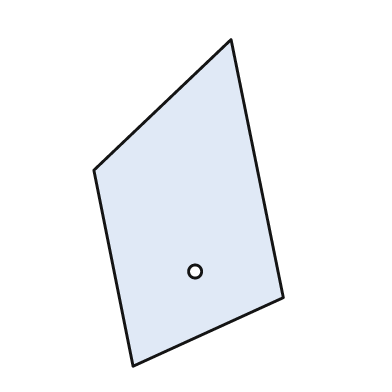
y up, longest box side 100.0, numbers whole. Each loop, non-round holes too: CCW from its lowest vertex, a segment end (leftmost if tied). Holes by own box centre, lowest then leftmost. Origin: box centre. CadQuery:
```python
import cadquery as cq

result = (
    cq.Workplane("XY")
    .moveTo(-17.0, -50.0)
    .lineTo(29.0, -29.0)
    .lineTo(13.0, 50.0)
    .lineTo(-29.0, 10.0)
    .close()
    .moveTo(2.0, -21.0)
    .circle(2.0)
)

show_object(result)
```